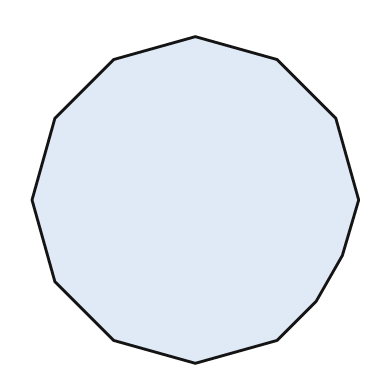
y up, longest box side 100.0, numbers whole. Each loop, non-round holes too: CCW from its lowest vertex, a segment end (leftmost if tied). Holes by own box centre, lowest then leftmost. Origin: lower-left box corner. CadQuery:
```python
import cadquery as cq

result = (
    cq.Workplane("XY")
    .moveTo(50.0, 0.0)
    .lineTo(75.0, 7.0)
    .lineTo(87.0, 19.0)
    .lineTo(95.0, 33.0)
    .lineTo(100.0, 50.0)
    .lineTo(93.0, 75.0)
    .lineTo(75.0, 93.0)
    .lineTo(50.0, 100.0)
    .lineTo(25.0, 93.0)
    .lineTo(7.0, 75.0)
    .lineTo(0.0, 50.0)
    .lineTo(7.0, 25.0)
    .lineTo(25.0, 7.0)
    .close()
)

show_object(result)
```